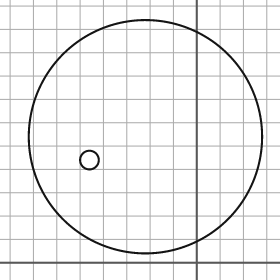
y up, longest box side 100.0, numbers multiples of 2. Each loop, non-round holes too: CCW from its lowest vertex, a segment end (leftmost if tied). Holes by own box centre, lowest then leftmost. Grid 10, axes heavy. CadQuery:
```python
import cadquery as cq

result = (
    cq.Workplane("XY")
    .moveTo(-22.0, 54.0)
    .circle(50.0)
    .moveTo(-46.0, 44.0)
    .circle(4.0)
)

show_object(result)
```